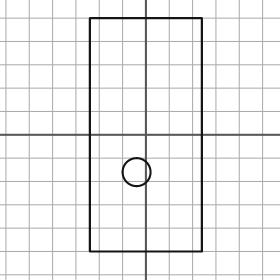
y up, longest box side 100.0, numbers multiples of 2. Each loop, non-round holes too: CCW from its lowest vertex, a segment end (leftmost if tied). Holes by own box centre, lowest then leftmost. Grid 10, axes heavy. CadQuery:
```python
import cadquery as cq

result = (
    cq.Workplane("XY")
    .moveTo(-24.0, -50.0)
    .lineTo(24.0, -50.0)
    .lineTo(24.0, 50.0)
    .lineTo(-24.0, 50.0)
    .close()
    .moveTo(-4.0, -16.0)
    .circle(6.0)
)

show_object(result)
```